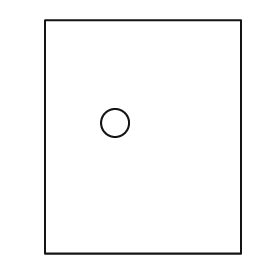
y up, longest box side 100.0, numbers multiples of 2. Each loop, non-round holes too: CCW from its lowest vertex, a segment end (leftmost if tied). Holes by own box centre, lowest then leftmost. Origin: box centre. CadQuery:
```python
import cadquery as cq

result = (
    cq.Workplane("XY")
    .moveTo(-42.0, -50.0)
    .lineTo(42.0, -50.0)
    .lineTo(42.0, 50.0)
    .lineTo(-42.0, 50.0)
    .close()
    .moveTo(-12.0, 6.0)
    .circle(6.0)
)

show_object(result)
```